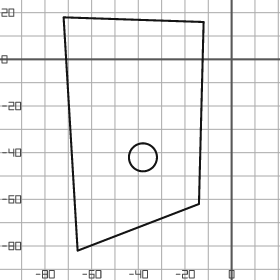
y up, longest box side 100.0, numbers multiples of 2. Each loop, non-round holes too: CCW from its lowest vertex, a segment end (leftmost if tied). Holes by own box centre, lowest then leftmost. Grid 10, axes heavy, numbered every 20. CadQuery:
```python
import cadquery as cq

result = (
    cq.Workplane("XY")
    .moveTo(-66.0, -82.0)
    .lineTo(-14.0, -62.0)
    .lineTo(-12.0, 16.0)
    .lineTo(-72.0, 18.0)
    .close()
    .moveTo(-38.0, -42.0)
    .circle(6.0)
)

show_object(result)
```